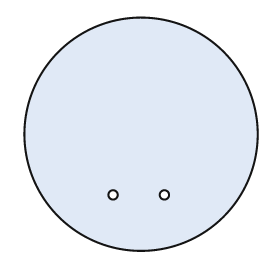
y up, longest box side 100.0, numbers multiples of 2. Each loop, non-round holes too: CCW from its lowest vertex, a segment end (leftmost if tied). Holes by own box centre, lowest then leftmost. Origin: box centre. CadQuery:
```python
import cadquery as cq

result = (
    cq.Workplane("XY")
    .moveTo(0.0, 0.0)
    .circle(50.0)
    .moveTo(-12.0, -26.0)
    .circle(2.0)
    .moveTo(10.0, -26.0)
    .circle(2.0)
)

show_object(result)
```